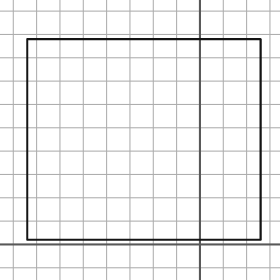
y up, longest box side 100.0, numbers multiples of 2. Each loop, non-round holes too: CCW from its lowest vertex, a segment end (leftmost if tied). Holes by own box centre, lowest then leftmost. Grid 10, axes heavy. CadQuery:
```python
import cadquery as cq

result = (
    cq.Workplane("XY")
    .moveTo(-74.0, 2.0)
    .lineTo(26.0, 2.0)
    .lineTo(26.0, 88.0)
    .lineTo(-74.0, 88.0)
    .close()
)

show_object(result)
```